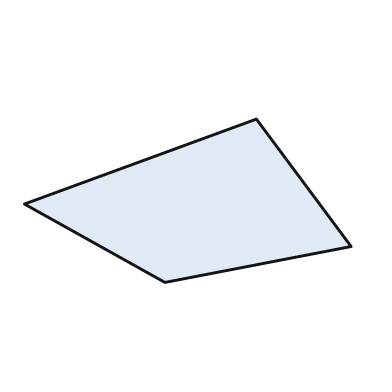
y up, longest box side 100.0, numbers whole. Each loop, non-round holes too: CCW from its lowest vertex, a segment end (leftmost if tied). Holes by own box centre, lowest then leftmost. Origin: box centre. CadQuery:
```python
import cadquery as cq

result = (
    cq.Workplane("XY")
    .moveTo(-7.0, -25.0)
    .lineTo(50.0, -14.0)
    .lineTo(21.0, 25.0)
    .lineTo(-50.0, -1.0)
    .close()
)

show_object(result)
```